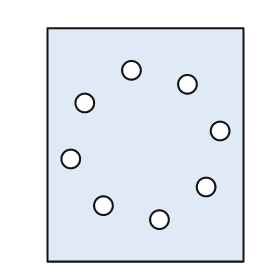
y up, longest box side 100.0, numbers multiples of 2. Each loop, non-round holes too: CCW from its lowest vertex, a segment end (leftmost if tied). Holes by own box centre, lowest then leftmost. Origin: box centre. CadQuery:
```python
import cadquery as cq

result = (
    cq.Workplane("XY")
    .moveTo(-42.0, -50.0)
    .lineTo(42.0, -50.0)
    .lineTo(42.0, 50.0)
    .lineTo(-42.0, 50.0)
    .close()
    .moveTo(6.0, -32.0)
    .circle(4.0)
    .moveTo(-18.0, -26.0)
    .circle(4.0)
    .moveTo(26.0, -18.0)
    .circle(4.0)
    .moveTo(-32.0, -6.0)
    .circle(4.0)
    .moveTo(32.0, 6.0)
    .circle(4.0)
    .moveTo(-26.0, 18.0)
    .circle(4.0)
    .moveTo(18.0, 26.0)
    .circle(4.0)
    .moveTo(-6.0, 32.0)
    .circle(4.0)
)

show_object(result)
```